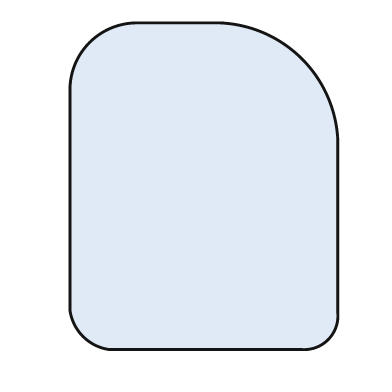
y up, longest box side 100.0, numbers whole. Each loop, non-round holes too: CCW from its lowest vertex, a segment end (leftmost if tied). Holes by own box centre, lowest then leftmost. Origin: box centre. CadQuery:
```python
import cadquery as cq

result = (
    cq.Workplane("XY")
    .moveTo(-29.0, -50.0)
    .lineTo(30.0, -50.0)
    .threePointArc((38.0, -47.0), (41.0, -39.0))
    .lineTo(41.0, 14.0)
    .threePointArc((30.0, 39.0), (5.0, 50.0))
    .lineTo(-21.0, 50.0)
    .threePointArc((-35.0, 44.0), (-41.0, 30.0))
    .lineTo(-41.0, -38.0)
    .threePointArc((-37.0, -46.0), (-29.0, -50.0))
    .close()
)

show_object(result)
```